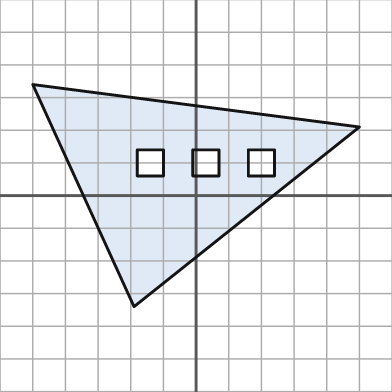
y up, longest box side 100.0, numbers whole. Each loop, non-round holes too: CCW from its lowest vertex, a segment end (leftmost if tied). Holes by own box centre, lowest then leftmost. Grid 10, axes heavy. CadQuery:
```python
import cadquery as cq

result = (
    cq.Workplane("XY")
    .moveTo(-19.0, -34.0)
    .lineTo(50.0, 21.0)
    .lineTo(-50.0, 34.0)
    .close()
    .moveTo(-18.0, 6.0)
    .lineTo(-10.0, 6.0)
    .lineTo(-10.0, 14.0)
    .lineTo(-18.0, 14.0)
    .close()
    .moveTo(-1.0, 6.0)
    .lineTo(7.0, 6.0)
    .lineTo(7.0, 14.0)
    .lineTo(-1.0, 14.0)
    .close()
    .moveTo(16.0, 6.0)
    .lineTo(24.0, 6.0)
    .lineTo(24.0, 14.0)
    .lineTo(16.0, 14.0)
    .close()
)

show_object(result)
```